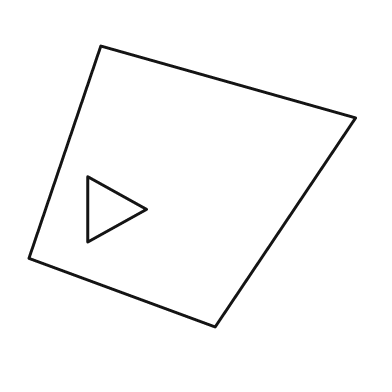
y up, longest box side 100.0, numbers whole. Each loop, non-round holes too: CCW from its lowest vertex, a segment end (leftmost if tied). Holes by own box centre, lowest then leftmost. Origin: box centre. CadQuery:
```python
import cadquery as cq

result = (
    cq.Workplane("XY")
    .moveTo(7.0, -43.0)
    .lineTo(50.0, 21.0)
    .lineTo(-28.0, 43.0)
    .lineTo(-50.0, -22.0)
    .close()
    .moveTo(-32.0, -17.0)
    .lineTo(-14.0, -7.0)
    .lineTo(-32.0, 3.0)
    .close()
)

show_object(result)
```